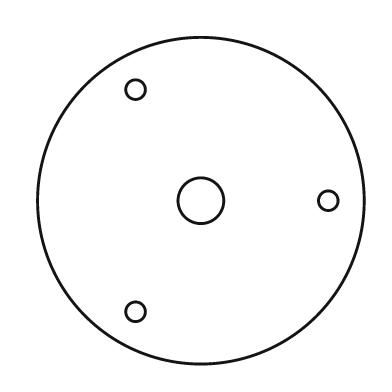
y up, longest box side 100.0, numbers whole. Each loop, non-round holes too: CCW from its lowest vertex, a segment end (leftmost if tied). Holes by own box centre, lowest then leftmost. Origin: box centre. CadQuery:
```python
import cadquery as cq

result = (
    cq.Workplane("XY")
    .moveTo(0.0, 0.0)
    .circle(50.0)
    .moveTo(-20.0, -34.0)
    .circle(3.0)
    .moveTo(0.0, 0.0)
    .circle(7.0)
    .moveTo(39.0, 0.0)
    .circle(3.0)
    .moveTo(-20.0, 34.0)
    .circle(3.0)
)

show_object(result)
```